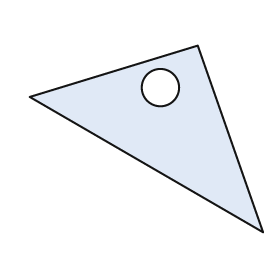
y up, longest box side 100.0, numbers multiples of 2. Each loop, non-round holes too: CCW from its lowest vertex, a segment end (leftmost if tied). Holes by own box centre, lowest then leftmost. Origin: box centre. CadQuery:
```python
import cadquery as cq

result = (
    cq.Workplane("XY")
    .moveTo(50.0, -40.0)
    .lineTo(22.0, 40.0)
    .lineTo(-50.0, 18.0)
    .close()
    .moveTo(6.0, 22.0)
    .circle(8.0)
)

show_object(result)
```